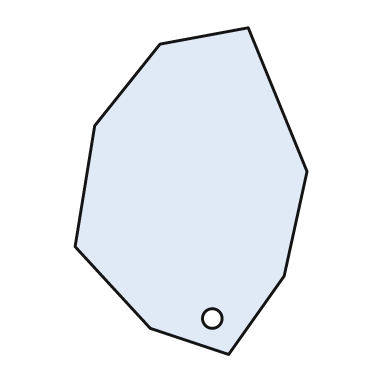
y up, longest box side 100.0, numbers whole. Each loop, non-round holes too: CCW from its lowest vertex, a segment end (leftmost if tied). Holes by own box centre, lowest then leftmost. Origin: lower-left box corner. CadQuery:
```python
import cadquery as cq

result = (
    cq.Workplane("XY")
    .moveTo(47.0, 0.0)
    .lineTo(64.0, 24.0)
    .lineTo(71.0, 56.0)
    .lineTo(53.0, 100.0)
    .lineTo(26.0, 95.0)
    .lineTo(6.0, 70.0)
    .lineTo(0.0, 33.0)
    .lineTo(23.0, 8.0)
    .close()
    .moveTo(42.0, 11.0)
    .circle(3.0)
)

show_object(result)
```